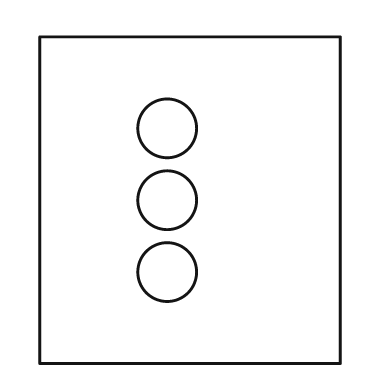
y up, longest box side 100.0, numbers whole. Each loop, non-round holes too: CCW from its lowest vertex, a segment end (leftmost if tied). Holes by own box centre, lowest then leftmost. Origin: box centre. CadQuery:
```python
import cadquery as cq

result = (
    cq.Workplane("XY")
    .moveTo(-46.0, -50.0)
    .lineTo(46.0, -50.0)
    .lineTo(46.0, 50.0)
    .lineTo(-46.0, 50.0)
    .close()
    .moveTo(-7.0, -22.0)
    .circle(9.0)
    .moveTo(-7.0, 0.0)
    .circle(9.0)
    .moveTo(-7.0, 22.0)
    .circle(9.0)
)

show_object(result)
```